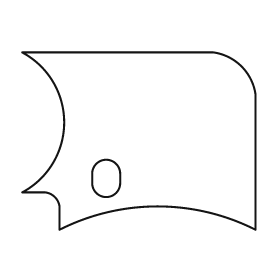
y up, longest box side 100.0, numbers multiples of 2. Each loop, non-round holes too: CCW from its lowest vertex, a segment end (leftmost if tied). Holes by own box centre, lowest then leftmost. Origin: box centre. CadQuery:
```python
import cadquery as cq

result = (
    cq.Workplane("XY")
    .moveTo(-34.0, -38.0)
    .threePointArc((8.0, -28.0), (50.0, -38.0))
    .lineTo(50.0, 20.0)
    .threePointArc((44.0, 32.0), (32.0, 38.0))
    .lineTo(-50.0, 38.0)
    .threePointArc((-32.0, 8.0), (-50.0, -22.0))
    .lineTo(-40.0, -22.0)
    .threePointArc((-36.0, -24.0), (-34.0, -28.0))
    .close()
    .moveTo(-20.0, -18.0)
    .threePointArc((-14.0, -24.0), (-8.0, -18.0))
    .lineTo(-8.0, -14.0)
    .threePointArc((-14.0, -8.0), (-20.0, -14.0))
    .close()
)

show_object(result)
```